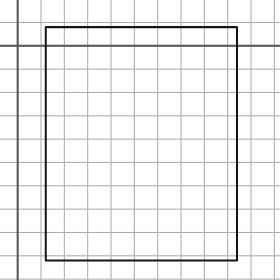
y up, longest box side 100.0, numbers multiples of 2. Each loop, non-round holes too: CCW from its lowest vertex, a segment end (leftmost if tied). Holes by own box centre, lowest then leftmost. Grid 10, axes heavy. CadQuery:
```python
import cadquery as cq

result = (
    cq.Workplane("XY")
    .moveTo(12.0, -92.0)
    .lineTo(94.0, -92.0)
    .lineTo(94.0, 8.0)
    .lineTo(12.0, 8.0)
    .close()
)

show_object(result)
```